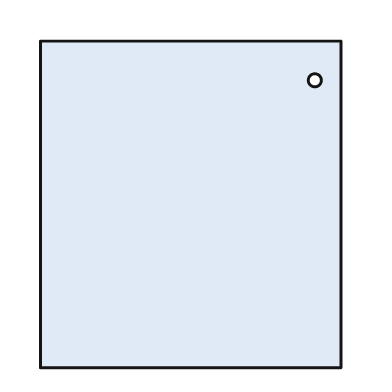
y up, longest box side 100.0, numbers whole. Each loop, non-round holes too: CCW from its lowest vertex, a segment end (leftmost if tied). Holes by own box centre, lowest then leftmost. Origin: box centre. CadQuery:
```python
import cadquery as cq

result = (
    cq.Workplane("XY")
    .moveTo(-46.0, -50.0)
    .lineTo(46.0, -50.0)
    .lineTo(46.0, 50.0)
    .lineTo(-46.0, 50.0)
    .close()
    .moveTo(38.0, 38.0)
    .circle(2.0)
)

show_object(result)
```